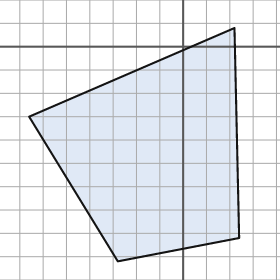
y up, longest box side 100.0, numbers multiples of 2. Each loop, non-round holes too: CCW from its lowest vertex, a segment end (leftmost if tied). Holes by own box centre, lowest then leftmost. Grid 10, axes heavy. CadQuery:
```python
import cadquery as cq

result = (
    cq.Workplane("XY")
    .moveTo(-28.0, -92.0)
    .lineTo(24.0, -82.0)
    .lineTo(22.0, 8.0)
    .lineTo(-66.0, -30.0)
    .close()
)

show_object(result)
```